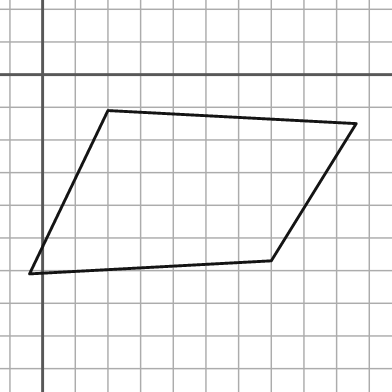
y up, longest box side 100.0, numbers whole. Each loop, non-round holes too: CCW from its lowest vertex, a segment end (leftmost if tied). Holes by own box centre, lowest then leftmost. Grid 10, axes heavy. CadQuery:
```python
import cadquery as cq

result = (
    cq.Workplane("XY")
    .moveTo(-4.0, -61.0)
    .lineTo(70.0, -57.0)
    .lineTo(96.0, -15.0)
    .lineTo(20.0, -11.0)
    .close()
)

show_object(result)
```